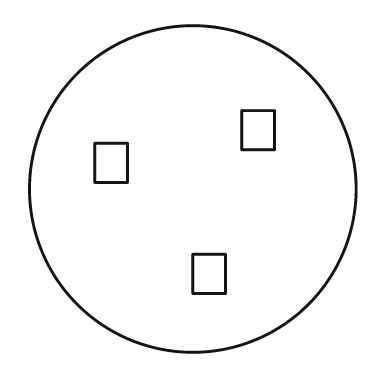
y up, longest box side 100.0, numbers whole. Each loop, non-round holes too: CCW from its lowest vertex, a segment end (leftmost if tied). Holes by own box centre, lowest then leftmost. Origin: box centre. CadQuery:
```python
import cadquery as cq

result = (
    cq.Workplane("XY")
    .moveTo(0.0, 0.0)
    .circle(50.0)
    .moveTo(0.0, -32.0)
    .lineTo(10.0, -32.0)
    .lineTo(10.0, -20.0)
    .lineTo(0.0, -20.0)
    .close()
    .moveTo(-30.0, 2.0)
    .lineTo(-20.0, 2.0)
    .lineTo(-20.0, 14.0)
    .lineTo(-30.0, 14.0)
    .close()
    .moveTo(15.0, 12.0)
    .lineTo(25.0, 12.0)
    .lineTo(25.0, 24.0)
    .lineTo(15.0, 24.0)
    .close()
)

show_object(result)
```